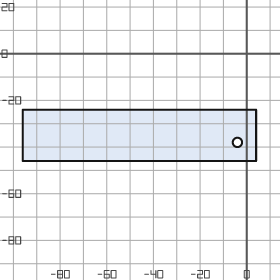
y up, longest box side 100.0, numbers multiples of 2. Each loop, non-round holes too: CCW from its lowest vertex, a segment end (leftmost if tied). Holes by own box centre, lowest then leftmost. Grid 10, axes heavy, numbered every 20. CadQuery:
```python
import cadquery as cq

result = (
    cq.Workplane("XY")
    .moveTo(-96.0, -46.0)
    .lineTo(4.0, -46.0)
    .lineTo(4.0, -24.0)
    .lineTo(-96.0, -24.0)
    .close()
    .moveTo(-4.0, -38.0)
    .circle(2.0)
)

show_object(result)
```